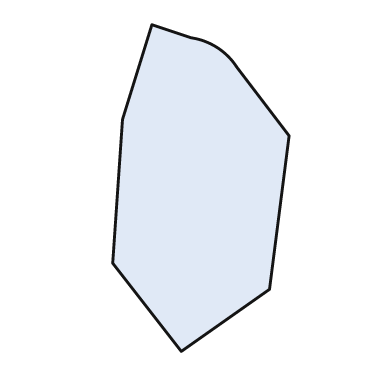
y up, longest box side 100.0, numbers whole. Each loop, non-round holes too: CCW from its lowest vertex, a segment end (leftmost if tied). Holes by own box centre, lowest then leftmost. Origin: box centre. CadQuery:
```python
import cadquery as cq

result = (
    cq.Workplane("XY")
    .moveTo(-6.0, -50.0)
    .lineTo(21.0, -31.0)
    .lineTo(27.0, 16.0)
    .lineTo(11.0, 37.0)
    .threePointArc((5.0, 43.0), (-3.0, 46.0))
    .lineTo(-15.0, 50.0)
    .lineTo(-24.0, 21.0)
    .lineTo(-27.0, -23.0)
    .close()
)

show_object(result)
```